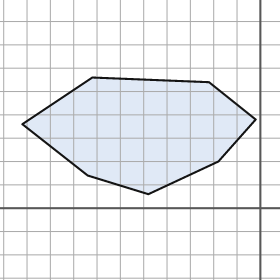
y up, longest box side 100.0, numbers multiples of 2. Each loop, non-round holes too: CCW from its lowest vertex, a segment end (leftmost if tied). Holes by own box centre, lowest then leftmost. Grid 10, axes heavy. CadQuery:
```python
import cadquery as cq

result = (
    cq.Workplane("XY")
    .moveTo(-48.0, 6.0)
    .lineTo(-18.0, 20.0)
    .lineTo(-2.0, 38.0)
    .lineTo(-22.0, 54.0)
    .lineTo(-72.0, 56.0)
    .lineTo(-102.0, 36.0)
    .lineTo(-74.0, 14.0)
    .close()
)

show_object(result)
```